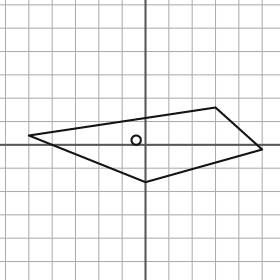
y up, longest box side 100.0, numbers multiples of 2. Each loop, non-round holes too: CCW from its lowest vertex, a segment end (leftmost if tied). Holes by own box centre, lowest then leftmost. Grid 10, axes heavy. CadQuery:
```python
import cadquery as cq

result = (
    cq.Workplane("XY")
    .moveTo(0.0, -16.0)
    .lineTo(50.0, -2.0)
    .lineTo(30.0, 16.0)
    .lineTo(-50.0, 4.0)
    .close()
    .moveTo(-4.0, 2.0)
    .circle(2.0)
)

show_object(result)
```